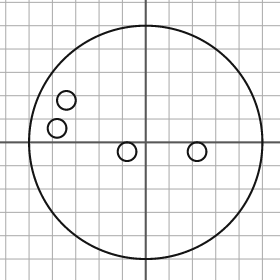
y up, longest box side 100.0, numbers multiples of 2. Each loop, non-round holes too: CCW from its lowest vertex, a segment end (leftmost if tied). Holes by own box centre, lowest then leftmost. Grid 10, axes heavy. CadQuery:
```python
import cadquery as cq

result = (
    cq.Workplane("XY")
    .moveTo(0.0, 0.0)
    .circle(50.0)
    .moveTo(-8.0, -4.0)
    .circle(4.0)
    .moveTo(22.0, -4.0)
    .circle(4.0)
    .moveTo(-38.0, 6.0)
    .circle(4.0)
    .moveTo(-34.0, 18.0)
    .circle(4.0)
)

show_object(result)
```